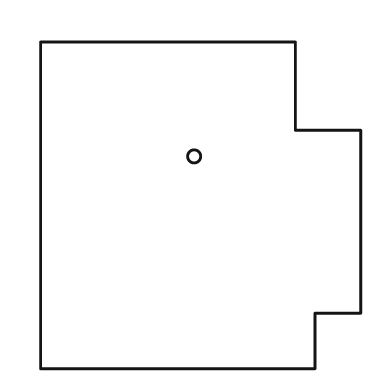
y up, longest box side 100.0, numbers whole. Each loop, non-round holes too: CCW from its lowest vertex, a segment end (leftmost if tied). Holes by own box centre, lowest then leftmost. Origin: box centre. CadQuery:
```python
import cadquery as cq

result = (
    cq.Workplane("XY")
    .moveTo(-49.0, -50.0)
    .lineTo(35.0, -50.0)
    .lineTo(35.0, -33.0)
    .lineTo(49.0, -33.0)
    .lineTo(49.0, 23.0)
    .lineTo(29.0, 23.0)
    .lineTo(29.0, 50.0)
    .lineTo(-49.0, 50.0)
    .close()
    .moveTo(-2.0, 15.0)
    .circle(2.0)
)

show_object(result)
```